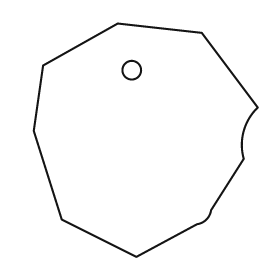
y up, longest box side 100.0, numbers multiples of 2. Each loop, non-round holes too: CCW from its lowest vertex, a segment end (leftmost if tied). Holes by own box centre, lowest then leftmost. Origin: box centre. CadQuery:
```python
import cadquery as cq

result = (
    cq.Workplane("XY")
    .moveTo(-4.0, -50.0)
    .lineTo(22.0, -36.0)
    .threePointArc((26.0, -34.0), (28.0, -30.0))
    .lineTo(42.0, -8.0)
    .threePointArc((42.0, 4.0), (48.0, 14.0))
    .lineTo(24.0, 46.0)
    .lineTo(-12.0, 50.0)
    .lineTo(-44.0, 32.0)
    .lineTo(-48.0, 4.0)
    .lineTo(-36.0, -34.0)
    .close()
    .moveTo(-6.0, 30.0)
    .circle(4.0)
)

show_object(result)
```